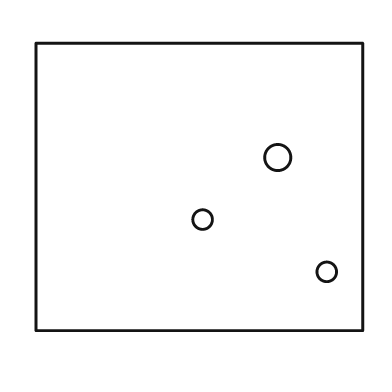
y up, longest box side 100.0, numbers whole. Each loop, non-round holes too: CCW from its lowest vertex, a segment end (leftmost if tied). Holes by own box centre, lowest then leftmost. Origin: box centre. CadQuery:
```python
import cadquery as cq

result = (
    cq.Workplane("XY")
    .moveTo(-50.0, -44.0)
    .lineTo(50.0, -44.0)
    .lineTo(50.0, 44.0)
    .lineTo(-50.0, 44.0)
    .close()
    .moveTo(39.0, -26.0)
    .circle(3.0)
    .moveTo(1.0, -10.0)
    .circle(3.0)
    .moveTo(24.0, 9.0)
    .circle(4.0)
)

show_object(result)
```